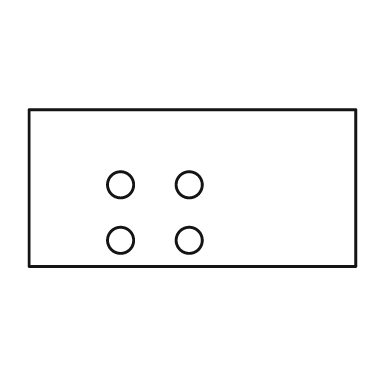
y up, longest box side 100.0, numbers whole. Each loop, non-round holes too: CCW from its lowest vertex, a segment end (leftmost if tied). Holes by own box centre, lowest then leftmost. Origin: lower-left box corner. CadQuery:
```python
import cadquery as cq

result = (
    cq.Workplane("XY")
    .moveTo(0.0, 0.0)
    .lineTo(100.0, 0.0)
    .lineTo(100.0, 48.0)
    .lineTo(0.0, 48.0)
    .close()
    .moveTo(28.0, 8.0)
    .circle(4.0)
    .moveTo(49.0, 8.0)
    .circle(4.0)
    .moveTo(28.0, 25.0)
    .circle(4.0)
    .moveTo(49.0, 25.0)
    .circle(4.0)
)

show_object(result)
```